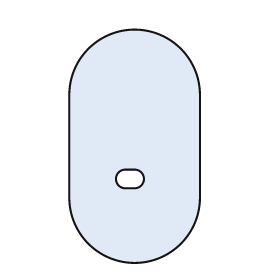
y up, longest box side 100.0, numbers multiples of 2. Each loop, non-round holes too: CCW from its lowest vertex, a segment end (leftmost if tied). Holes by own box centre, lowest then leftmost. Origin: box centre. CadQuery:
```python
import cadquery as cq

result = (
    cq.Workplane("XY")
    .moveTo(-28.0, -22.0)
    .threePointArc((0.0, -50.0), (28.0, -22.0))
    .lineTo(28.0, 22.0)
    .threePointArc((0.0, 50.0), (-28.0, 22.0))
    .close()
    .moveTo(-4.0, -18.0)
    .lineTo(0.0, -18.0)
    .threePointArc((4.0, -14.0), (0.0, -10.0))
    .lineTo(-4.0, -10.0)
    .threePointArc((-8.0, -14.0), (-4.0, -18.0))
    .close()
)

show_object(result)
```